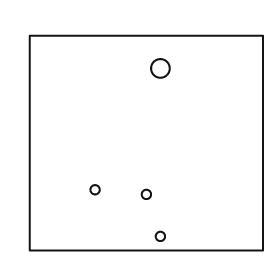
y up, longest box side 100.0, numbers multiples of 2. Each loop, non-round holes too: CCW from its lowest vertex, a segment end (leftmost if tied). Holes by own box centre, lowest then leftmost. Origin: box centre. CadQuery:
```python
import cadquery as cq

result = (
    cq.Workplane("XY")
    .moveTo(-50.0, -46.0)
    .lineTo(50.0, -46.0)
    .lineTo(50.0, 46.0)
    .lineTo(-50.0, 46.0)
    .close()
    .moveTo(6.0, -40.0)
    .circle(2.0)
    .moveTo(0.0, -22.0)
    .circle(2.0)
    .moveTo(-22.0, -20.0)
    .circle(2.0)
    .moveTo(6.0, 32.0)
    .circle(4.0)
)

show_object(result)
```